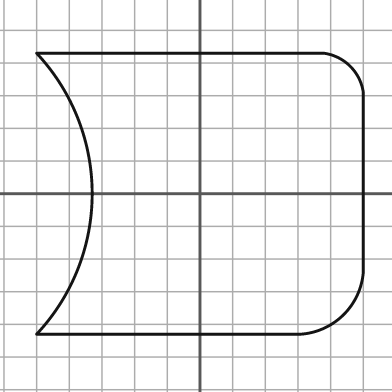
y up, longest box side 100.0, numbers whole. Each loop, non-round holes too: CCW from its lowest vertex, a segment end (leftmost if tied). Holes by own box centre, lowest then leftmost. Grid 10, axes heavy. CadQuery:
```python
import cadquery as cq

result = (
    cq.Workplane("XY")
    .moveTo(-50.0, -43.0)
    .lineTo(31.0, -43.0)
    .threePointArc((44.0, -37.0), (50.0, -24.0))
    .lineTo(50.0, 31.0)
    .threePointArc((46.0, 39.0), (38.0, 43.0))
    .lineTo(-50.0, 43.0)
    .threePointArc((-33.0, 0.0), (-50.0, -43.0))
    .close()
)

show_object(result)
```